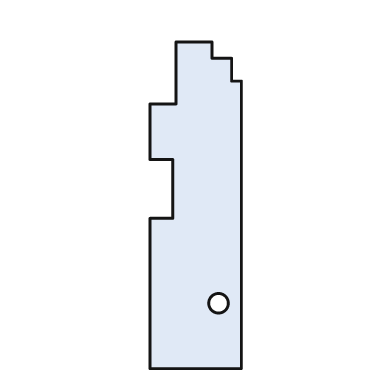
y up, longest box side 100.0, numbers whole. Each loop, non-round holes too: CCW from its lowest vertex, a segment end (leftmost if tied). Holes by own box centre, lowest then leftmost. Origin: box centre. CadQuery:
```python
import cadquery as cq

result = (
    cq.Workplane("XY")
    .moveTo(-14.0, -50.0)
    .lineTo(14.0, -50.0)
    .lineTo(14.0, 38.0)
    .lineTo(11.0, 38.0)
    .lineTo(11.0, 45.0)
    .lineTo(5.0, 45.0)
    .lineTo(5.0, 50.0)
    .lineTo(-6.0, 50.0)
    .lineTo(-6.0, 31.0)
    .lineTo(-14.0, 31.0)
    .lineTo(-14.0, 14.0)
    .lineTo(-7.0, 14.0)
    .lineTo(-7.0, -4.0)
    .lineTo(-14.0, -4.0)
    .close()
    .moveTo(7.0, -30.0)
    .circle(3.0)
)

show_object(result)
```